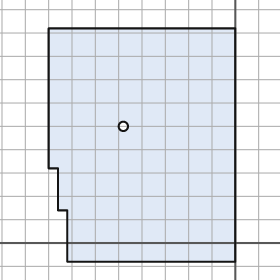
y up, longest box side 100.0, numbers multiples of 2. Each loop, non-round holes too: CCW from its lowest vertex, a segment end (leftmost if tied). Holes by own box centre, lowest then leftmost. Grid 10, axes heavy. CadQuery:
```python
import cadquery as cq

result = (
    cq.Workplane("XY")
    .moveTo(-72.0, -8.0)
    .lineTo(0.0, -8.0)
    .lineTo(0.0, 92.0)
    .lineTo(-80.0, 92.0)
    .lineTo(-80.0, 32.0)
    .lineTo(-76.0, 32.0)
    .lineTo(-76.0, 14.0)
    .lineTo(-72.0, 14.0)
    .close()
    .moveTo(-48.0, 50.0)
    .circle(2.0)
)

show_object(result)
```